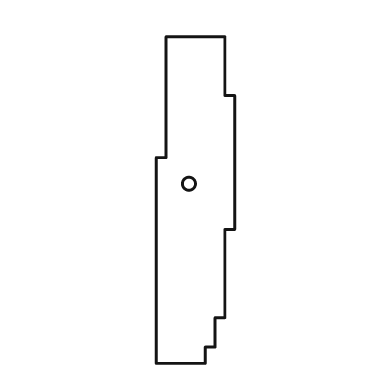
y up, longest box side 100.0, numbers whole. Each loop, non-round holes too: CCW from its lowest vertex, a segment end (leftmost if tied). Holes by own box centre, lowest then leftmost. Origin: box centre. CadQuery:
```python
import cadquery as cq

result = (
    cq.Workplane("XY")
    .moveTo(-12.0, -50.0)
    .lineTo(3.0, -50.0)
    .lineTo(3.0, -45.0)
    .lineTo(6.0, -45.0)
    .lineTo(6.0, -36.0)
    .lineTo(9.0, -36.0)
    .lineTo(9.0, -9.0)
    .lineTo(12.0, -9.0)
    .lineTo(12.0, 32.0)
    .lineTo(9.0, 32.0)
    .lineTo(9.0, 50.0)
    .lineTo(-9.0, 50.0)
    .lineTo(-9.0, 13.0)
    .lineTo(-12.0, 13.0)
    .close()
    .moveTo(-2.0, 5.0)
    .circle(2.0)
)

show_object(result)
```